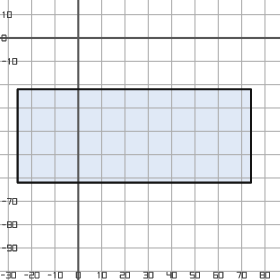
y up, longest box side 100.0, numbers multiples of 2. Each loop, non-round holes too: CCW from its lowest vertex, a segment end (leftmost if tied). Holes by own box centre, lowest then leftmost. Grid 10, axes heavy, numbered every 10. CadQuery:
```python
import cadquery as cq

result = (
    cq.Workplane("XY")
    .moveTo(-26.0, -62.0)
    .lineTo(74.0, -62.0)
    .lineTo(74.0, -22.0)
    .lineTo(-26.0, -22.0)
    .close()
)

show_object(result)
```